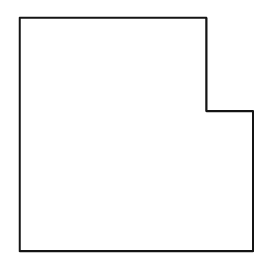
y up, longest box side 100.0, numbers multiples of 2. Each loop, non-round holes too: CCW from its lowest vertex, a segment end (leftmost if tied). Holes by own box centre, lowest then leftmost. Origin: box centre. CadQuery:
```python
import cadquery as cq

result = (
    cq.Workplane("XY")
    .moveTo(-50.0, -50.0)
    .lineTo(50.0, -50.0)
    .lineTo(50.0, 10.0)
    .lineTo(30.0, 10.0)
    .lineTo(30.0, 50.0)
    .lineTo(-50.0, 50.0)
    .close()
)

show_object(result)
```